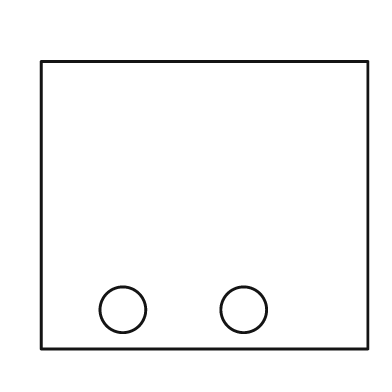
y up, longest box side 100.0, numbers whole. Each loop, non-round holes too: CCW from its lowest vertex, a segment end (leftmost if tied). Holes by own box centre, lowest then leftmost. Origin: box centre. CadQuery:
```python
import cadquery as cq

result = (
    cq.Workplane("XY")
    .moveTo(-50.0, -44.0)
    .lineTo(50.0, -44.0)
    .lineTo(50.0, 44.0)
    .lineTo(-50.0, 44.0)
    .close()
    .moveTo(-25.0, -32.0)
    .circle(7.0)
    .moveTo(12.0, -32.0)
    .circle(7.0)
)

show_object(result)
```